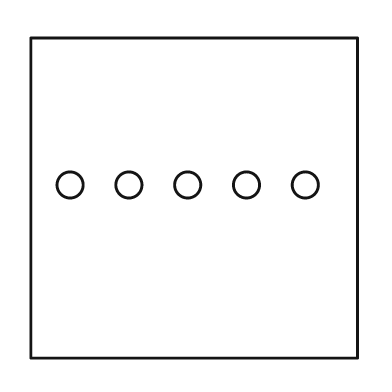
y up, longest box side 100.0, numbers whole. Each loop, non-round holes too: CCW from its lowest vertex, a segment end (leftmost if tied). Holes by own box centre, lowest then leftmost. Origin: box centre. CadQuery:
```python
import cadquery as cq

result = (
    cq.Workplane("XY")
    .moveTo(-50.0, -49.0)
    .lineTo(50.0, -49.0)
    .lineTo(50.0, 49.0)
    .lineTo(-50.0, 49.0)
    .close()
    .moveTo(-38.0, 4.0)
    .circle(4.0)
    .moveTo(-20.0, 4.0)
    .circle(4.0)
    .moveTo(-2.0, 4.0)
    .circle(4.0)
    .moveTo(16.0, 4.0)
    .circle(4.0)
    .moveTo(34.0, 4.0)
    .circle(4.0)
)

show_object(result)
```